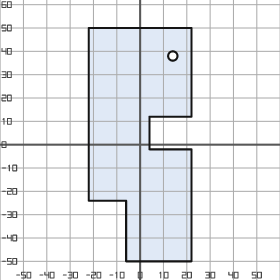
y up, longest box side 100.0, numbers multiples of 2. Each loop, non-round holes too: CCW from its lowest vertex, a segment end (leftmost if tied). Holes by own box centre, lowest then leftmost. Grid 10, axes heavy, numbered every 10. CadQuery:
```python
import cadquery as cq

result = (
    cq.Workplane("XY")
    .moveTo(-6.0, -50.0)
    .lineTo(22.0, -50.0)
    .lineTo(22.0, -2.0)
    .lineTo(4.0, -2.0)
    .lineTo(4.0, 12.0)
    .lineTo(22.0, 12.0)
    .lineTo(22.0, 50.0)
    .lineTo(-22.0, 50.0)
    .lineTo(-22.0, -24.0)
    .lineTo(-6.0, -24.0)
    .close()
    .moveTo(14.0, 38.0)
    .circle(2.0)
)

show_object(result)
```